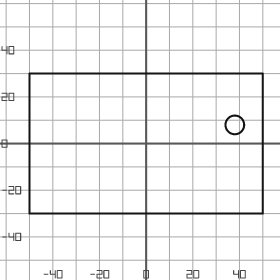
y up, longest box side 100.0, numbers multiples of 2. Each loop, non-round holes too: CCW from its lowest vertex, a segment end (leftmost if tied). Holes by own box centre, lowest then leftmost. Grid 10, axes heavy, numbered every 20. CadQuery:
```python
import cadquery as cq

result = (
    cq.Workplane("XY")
    .moveTo(-50.0, -30.0)
    .lineTo(50.0, -30.0)
    .lineTo(50.0, 30.0)
    .lineTo(-50.0, 30.0)
    .close()
    .moveTo(38.0, 8.0)
    .circle(4.0)
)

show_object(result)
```